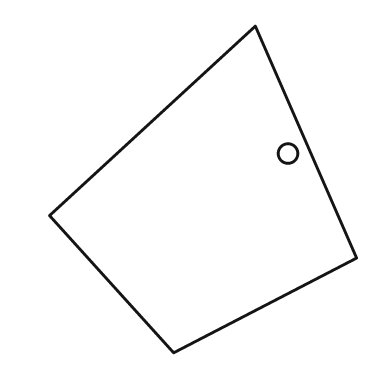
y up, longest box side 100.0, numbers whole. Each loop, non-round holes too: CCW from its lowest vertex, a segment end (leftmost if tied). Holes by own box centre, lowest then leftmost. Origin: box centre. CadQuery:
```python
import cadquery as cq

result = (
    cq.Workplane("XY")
    .moveTo(-9.0, -50.0)
    .lineTo(47.0, -21.0)
    .lineTo(16.0, 50.0)
    .lineTo(-47.0, -8.0)
    .close()
    .moveTo(26.0, 11.0)
    .circle(3.0)
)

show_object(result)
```